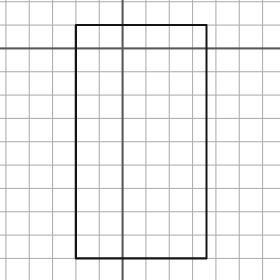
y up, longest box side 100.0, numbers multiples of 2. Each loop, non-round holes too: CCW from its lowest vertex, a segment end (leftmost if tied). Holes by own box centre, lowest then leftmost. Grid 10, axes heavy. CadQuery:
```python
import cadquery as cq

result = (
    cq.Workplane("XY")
    .moveTo(-20.0, -90.0)
    .lineTo(36.0, -90.0)
    .lineTo(36.0, 10.0)
    .lineTo(-20.0, 10.0)
    .close()
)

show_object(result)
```